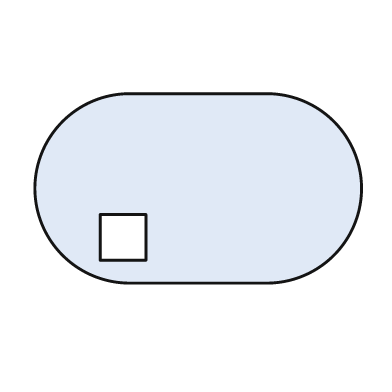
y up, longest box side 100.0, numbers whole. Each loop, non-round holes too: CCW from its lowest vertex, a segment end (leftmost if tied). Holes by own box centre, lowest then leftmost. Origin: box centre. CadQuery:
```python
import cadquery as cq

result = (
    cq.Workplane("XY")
    .moveTo(-21.0, -29.0)
    .lineTo(21.0, -29.0)
    .threePointArc((50.0, 0.0), (21.0, 29.0))
    .lineTo(-21.0, 29.0)
    .threePointArc((-50.0, 0.0), (-21.0, -29.0))
    .close()
    .moveTo(-30.0, -22.0)
    .lineTo(-16.0, -22.0)
    .lineTo(-16.0, -8.0)
    .lineTo(-30.0, -8.0)
    .close()
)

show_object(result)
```